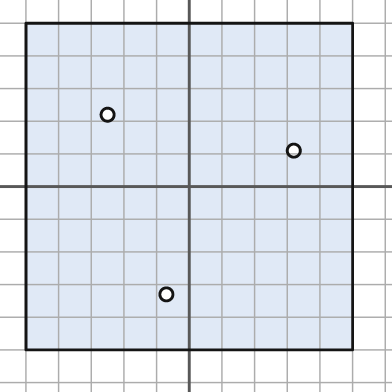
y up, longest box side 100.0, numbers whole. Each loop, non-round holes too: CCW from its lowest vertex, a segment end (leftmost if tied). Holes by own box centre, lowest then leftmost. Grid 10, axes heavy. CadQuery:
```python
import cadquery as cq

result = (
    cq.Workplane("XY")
    .moveTo(-50.0, -50.0)
    .lineTo(50.0, -50.0)
    .lineTo(50.0, 50.0)
    .lineTo(-50.0, 50.0)
    .close()
    .moveTo(-7.0, -33.0)
    .circle(2.0)
    .moveTo(32.0, 11.0)
    .circle(2.0)
    .moveTo(-25.0, 22.0)
    .circle(2.0)
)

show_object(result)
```